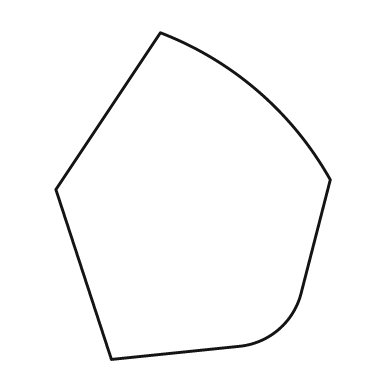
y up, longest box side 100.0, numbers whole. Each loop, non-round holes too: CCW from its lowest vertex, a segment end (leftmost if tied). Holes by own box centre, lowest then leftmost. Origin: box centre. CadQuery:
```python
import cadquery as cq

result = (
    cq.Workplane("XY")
    .moveTo(-25.0, -50.0)
    .lineTo(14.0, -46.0)
    .threePointArc((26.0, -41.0), (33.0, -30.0))
    .lineTo(42.0, 5.0)
    .threePointArc((20.0, 32.0), (-10.0, 50.0))
    .lineTo(-42.0, 2.0)
    .close()
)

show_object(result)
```